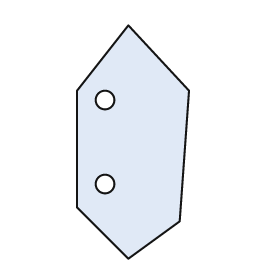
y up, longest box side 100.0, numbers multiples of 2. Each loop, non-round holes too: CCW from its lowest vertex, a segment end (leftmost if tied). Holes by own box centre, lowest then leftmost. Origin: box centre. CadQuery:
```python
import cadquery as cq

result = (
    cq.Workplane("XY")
    .moveTo(-2.0, -50.0)
    .lineTo(20.0, -34.0)
    .lineTo(24.0, 22.0)
    .lineTo(-2.0, 50.0)
    .lineTo(-24.0, 22.0)
    .lineTo(-24.0, -28.0)
    .close()
    .moveTo(-12.0, -18.0)
    .circle(4.0)
    .moveTo(-12.0, 18.0)
    .circle(4.0)
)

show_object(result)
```